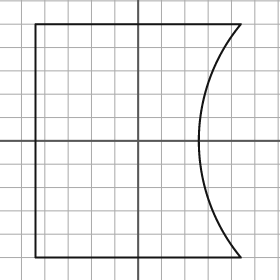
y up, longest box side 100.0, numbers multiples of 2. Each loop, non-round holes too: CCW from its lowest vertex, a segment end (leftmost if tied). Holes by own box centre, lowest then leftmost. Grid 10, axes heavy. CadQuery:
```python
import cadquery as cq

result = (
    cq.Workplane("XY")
    .moveTo(-44.0, -50.0)
    .lineTo(44.0, -50.0)
    .threePointArc((26.0, 0.0), (44.0, 50.0))
    .lineTo(-44.0, 50.0)
    .close()
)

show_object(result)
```